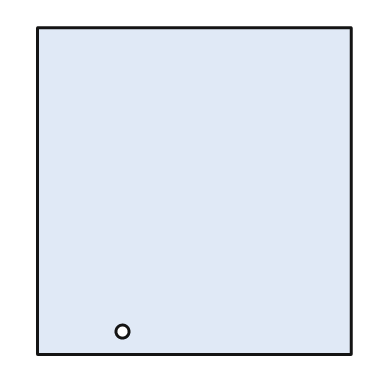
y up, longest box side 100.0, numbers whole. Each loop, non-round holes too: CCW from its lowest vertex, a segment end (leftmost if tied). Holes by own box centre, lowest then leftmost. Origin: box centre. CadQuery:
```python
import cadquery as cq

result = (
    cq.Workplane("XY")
    .moveTo(-48.0, -50.0)
    .lineTo(48.0, -50.0)
    .lineTo(48.0, 50.0)
    .lineTo(-48.0, 50.0)
    .close()
    .moveTo(-22.0, -43.0)
    .circle(2.0)
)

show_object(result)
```